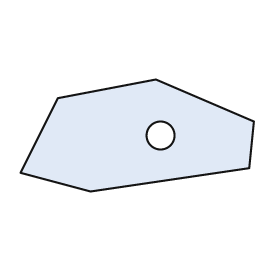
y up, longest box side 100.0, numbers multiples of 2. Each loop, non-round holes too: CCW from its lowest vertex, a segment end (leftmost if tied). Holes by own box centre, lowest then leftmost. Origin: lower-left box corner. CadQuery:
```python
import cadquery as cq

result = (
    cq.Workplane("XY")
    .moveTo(30.0, 0.0)
    .lineTo(98.0, 10.0)
    .lineTo(100.0, 30.0)
    .lineTo(58.0, 48.0)
    .lineTo(16.0, 40.0)
    .lineTo(0.0, 8.0)
    .close()
    .moveTo(60.0, 24.0)
    .circle(6.0)
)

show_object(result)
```